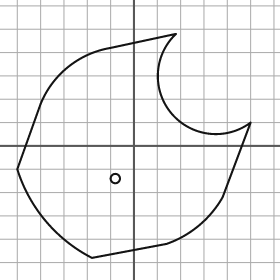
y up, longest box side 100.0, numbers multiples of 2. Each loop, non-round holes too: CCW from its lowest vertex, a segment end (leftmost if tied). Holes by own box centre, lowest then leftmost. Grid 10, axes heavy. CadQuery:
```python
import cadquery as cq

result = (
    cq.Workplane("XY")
    .moveTo(-18.0, -48.0)
    .lineTo(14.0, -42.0)
    .threePointArc((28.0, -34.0), (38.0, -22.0))
    .lineTo(50.0, 10.0)
    .threePointArc((16.0, 14.0), (18.0, 48.0))
    .lineTo(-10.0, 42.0)
    .threePointArc((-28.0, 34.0), (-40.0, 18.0))
    .lineTo(-50.0, -10.0)
    .threePointArc((-38.0, -32.0), (-18.0, -48.0))
    .close()
    .moveTo(-8.0, -14.0)
    .circle(2.0)
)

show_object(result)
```